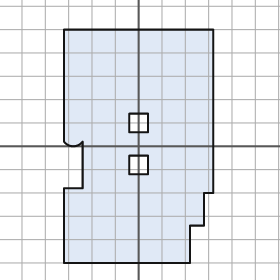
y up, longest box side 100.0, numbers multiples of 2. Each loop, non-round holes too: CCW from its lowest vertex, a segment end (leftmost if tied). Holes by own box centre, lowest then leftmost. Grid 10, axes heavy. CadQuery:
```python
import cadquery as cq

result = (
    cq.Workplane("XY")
    .moveTo(-32.0, -50.0)
    .lineTo(22.0, -50.0)
    .lineTo(22.0, -34.0)
    .lineTo(28.0, -34.0)
    .lineTo(28.0, -20.0)
    .lineTo(32.0, -20.0)
    .lineTo(32.0, 50.0)
    .lineTo(-32.0, 50.0)
    .lineTo(-32.0, 2.0)
    .threePointArc((-28.0, 0.0), (-24.0, 2.0))
    .lineTo(-24.0, -18.0)
    .lineTo(-32.0, -18.0)
    .close()
    .moveTo(-4.0, -12.0)
    .lineTo(4.0, -12.0)
    .lineTo(4.0, -4.0)
    .lineTo(-4.0, -4.0)
    .close()
    .moveTo(-4.0, 6.0)
    .lineTo(4.0, 6.0)
    .lineTo(4.0, 14.0)
    .lineTo(-4.0, 14.0)
    .close()
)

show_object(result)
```